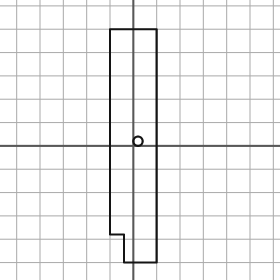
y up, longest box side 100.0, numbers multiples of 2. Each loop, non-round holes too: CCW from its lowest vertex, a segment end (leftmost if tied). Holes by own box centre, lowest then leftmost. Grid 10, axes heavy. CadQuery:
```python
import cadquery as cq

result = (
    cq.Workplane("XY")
    .moveTo(-4.0, -50.0)
    .lineTo(10.0, -50.0)
    .lineTo(10.0, 50.0)
    .lineTo(-10.0, 50.0)
    .lineTo(-10.0, -38.0)
    .lineTo(-4.0, -38.0)
    .close()
    .moveTo(2.0, 2.0)
    .circle(2.0)
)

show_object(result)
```